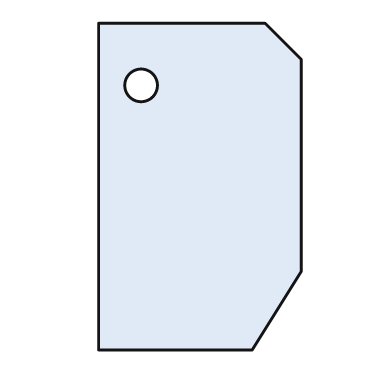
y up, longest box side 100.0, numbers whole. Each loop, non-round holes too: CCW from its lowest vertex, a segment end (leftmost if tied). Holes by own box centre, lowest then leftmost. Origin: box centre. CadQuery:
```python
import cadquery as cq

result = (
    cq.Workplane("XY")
    .moveTo(-31.0, -50.0)
    .lineTo(16.0, -50.0)
    .lineTo(31.0, -26.0)
    .lineTo(31.0, 39.0)
    .lineTo(20.0, 50.0)
    .lineTo(-31.0, 50.0)
    .close()
    .moveTo(-18.0, 31.0)
    .circle(5.0)
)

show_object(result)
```